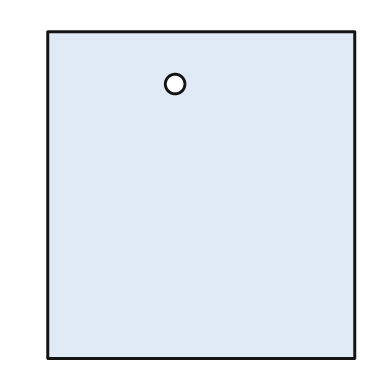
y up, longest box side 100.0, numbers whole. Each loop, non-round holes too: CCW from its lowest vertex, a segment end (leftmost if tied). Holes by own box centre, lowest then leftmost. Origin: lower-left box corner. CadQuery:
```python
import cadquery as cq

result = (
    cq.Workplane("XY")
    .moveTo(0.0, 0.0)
    .lineTo(94.0, 0.0)
    .lineTo(94.0, 100.0)
    .lineTo(0.0, 100.0)
    .close()
    .moveTo(39.0, 84.0)
    .circle(3.0)
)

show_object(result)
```